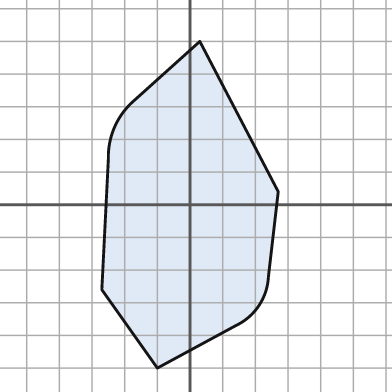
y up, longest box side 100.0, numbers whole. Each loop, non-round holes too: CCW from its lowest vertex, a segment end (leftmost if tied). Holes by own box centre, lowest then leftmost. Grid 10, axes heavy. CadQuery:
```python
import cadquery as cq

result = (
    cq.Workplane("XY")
    .moveTo(-10.0, -50.0)
    .lineTo(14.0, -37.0)
    .threePointArc((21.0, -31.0), (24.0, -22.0))
    .lineTo(27.0, 4.0)
    .lineTo(3.0, 50.0)
    .lineTo(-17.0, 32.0)
    .threePointArc((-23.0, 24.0), (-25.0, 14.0))
    .lineTo(-27.0, -26.0)
    .close()
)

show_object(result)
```